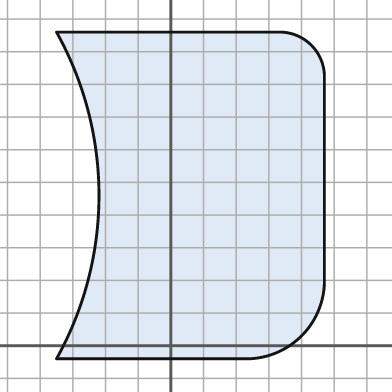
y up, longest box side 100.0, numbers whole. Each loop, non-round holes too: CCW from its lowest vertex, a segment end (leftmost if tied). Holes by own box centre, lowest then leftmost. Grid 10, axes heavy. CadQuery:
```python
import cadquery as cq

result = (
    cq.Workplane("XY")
    .moveTo(-35.0, -4.0)
    .lineTo(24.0, -4.0)
    .threePointArc((40.0, 3.0), (47.0, 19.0))
    .lineTo(47.0, 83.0)
    .threePointArc((43.0, 92.0), (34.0, 96.0))
    .lineTo(-35.0, 96.0)
    .threePointArc((-22.0, 46.0), (-35.0, -4.0))
    .close()
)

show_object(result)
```